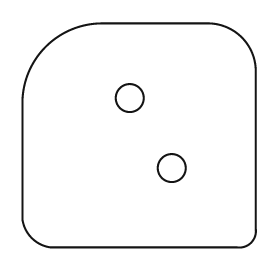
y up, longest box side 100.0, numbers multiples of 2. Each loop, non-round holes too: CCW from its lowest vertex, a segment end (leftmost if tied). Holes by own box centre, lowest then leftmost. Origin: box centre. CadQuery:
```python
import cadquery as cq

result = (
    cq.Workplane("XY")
    .moveTo(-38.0, -48.0)
    .lineTo(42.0, -48.0)
    .threePointArc((48.0, -46.0), (50.0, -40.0))
    .lineTo(50.0, 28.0)
    .threePointArc((44.0, 42.0), (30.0, 48.0))
    .lineTo(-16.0, 48.0)
    .threePointArc((-40.0, 38.0), (-50.0, 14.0))
    .lineTo(-50.0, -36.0)
    .threePointArc((-46.0, -44.0), (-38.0, -48.0))
    .close()
    .moveTo(14.0, -14.0)
    .circle(6.0)
    .moveTo(-4.0, 16.0)
    .circle(6.0)
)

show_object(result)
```